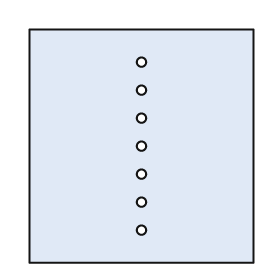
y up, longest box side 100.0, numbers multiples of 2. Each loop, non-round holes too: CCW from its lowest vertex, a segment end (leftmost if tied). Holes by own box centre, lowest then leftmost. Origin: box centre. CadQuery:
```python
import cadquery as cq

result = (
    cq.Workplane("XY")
    .moveTo(-48.0, -50.0)
    .lineTo(48.0, -50.0)
    .lineTo(48.0, 50.0)
    .lineTo(-48.0, 50.0)
    .close()
    .moveTo(0.0, -36.0)
    .circle(2.0)
    .moveTo(0.0, -24.0)
    .circle(2.0)
    .moveTo(0.0, -12.0)
    .circle(2.0)
    .moveTo(0.0, 0.0)
    .circle(2.0)
    .moveTo(0.0, 12.0)
    .circle(2.0)
    .moveTo(0.0, 24.0)
    .circle(2.0)
    .moveTo(0.0, 36.0)
    .circle(2.0)
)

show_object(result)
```